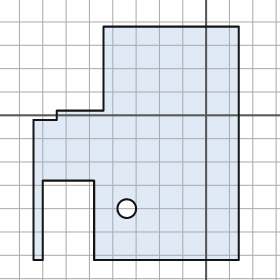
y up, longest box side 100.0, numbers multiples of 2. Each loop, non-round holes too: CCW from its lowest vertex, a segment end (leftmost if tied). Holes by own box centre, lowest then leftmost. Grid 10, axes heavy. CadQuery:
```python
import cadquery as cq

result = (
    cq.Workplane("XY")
    .moveTo(-74.0, -62.0)
    .lineTo(-70.0, -62.0)
    .lineTo(-70.0, -28.0)
    .lineTo(-48.0, -28.0)
    .lineTo(-48.0, -62.0)
    .lineTo(14.0, -62.0)
    .lineTo(14.0, 38.0)
    .lineTo(-44.0, 38.0)
    .lineTo(-44.0, 2.0)
    .lineTo(-64.0, 2.0)
    .lineTo(-64.0, -2.0)
    .lineTo(-74.0, -2.0)
    .close()
    .moveTo(-34.0, -40.0)
    .circle(4.0)
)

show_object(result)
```